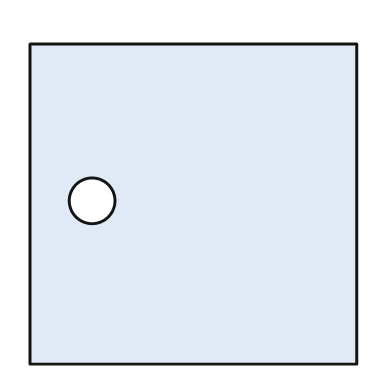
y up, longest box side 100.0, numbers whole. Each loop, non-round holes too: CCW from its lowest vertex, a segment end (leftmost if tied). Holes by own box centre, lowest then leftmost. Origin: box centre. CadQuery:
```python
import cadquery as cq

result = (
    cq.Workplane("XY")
    .moveTo(-50.0, -49.0)
    .lineTo(50.0, -49.0)
    .lineTo(50.0, 49.0)
    .lineTo(-50.0, 49.0)
    .close()
    .moveTo(-31.0, 1.0)
    .circle(7.0)
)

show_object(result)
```